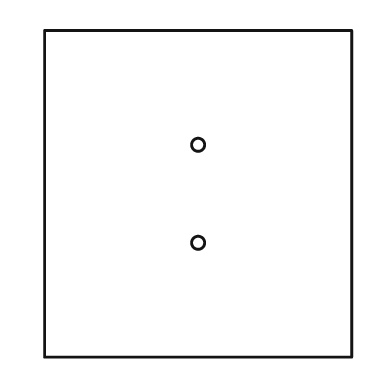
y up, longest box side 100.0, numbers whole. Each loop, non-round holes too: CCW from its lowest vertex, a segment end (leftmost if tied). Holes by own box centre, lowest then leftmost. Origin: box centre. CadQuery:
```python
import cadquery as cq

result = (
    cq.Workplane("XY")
    .moveTo(-47.0, -50.0)
    .lineTo(47.0, -50.0)
    .lineTo(47.0, 50.0)
    .lineTo(-47.0, 50.0)
    .close()
    .moveTo(0.0, -15.0)
    .circle(2.0)
    .moveTo(0.0, 15.0)
    .circle(2.0)
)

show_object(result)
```